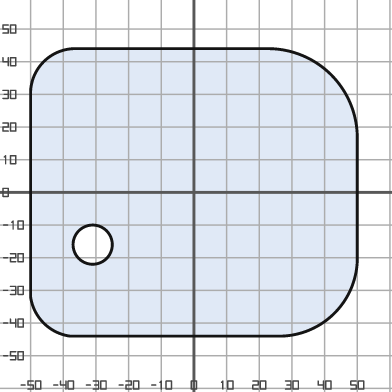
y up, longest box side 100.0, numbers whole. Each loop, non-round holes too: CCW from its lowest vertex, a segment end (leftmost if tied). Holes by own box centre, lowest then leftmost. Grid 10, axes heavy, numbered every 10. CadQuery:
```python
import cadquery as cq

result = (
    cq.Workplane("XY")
    .moveTo(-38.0, -44.0)
    .lineTo(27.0, -44.0)
    .threePointArc((43.0, -37.0), (50.0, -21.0))
    .lineTo(50.0, 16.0)
    .threePointArc((42.0, 36.0), (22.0, 44.0))
    .lineTo(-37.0, 44.0)
    .threePointArc((-46.0, 40.0), (-50.0, 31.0))
    .lineTo(-50.0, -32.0)
    .threePointArc((-46.0, -40.0), (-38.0, -44.0))
    .close()
    .moveTo(-31.0, -16.0)
    .circle(6.0)
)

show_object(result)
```